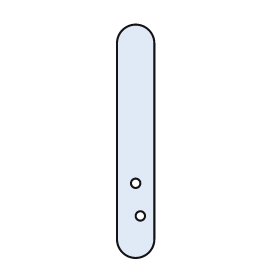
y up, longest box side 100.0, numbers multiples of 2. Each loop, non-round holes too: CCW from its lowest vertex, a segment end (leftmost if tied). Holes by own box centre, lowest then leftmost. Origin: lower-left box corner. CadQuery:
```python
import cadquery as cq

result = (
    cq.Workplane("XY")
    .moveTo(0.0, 8.0)
    .threePointArc((8.0, 0.0), (16.0, 8.0))
    .lineTo(16.0, 92.0)
    .threePointArc((8.0, 100.0), (0.0, 92.0))
    .close()
    .moveTo(10.0, 18.0)
    .circle(2.0)
    .moveTo(8.0, 32.0)
    .circle(2.0)
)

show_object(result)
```